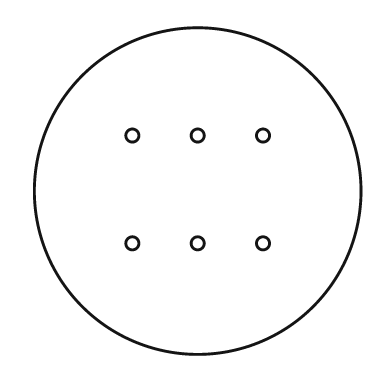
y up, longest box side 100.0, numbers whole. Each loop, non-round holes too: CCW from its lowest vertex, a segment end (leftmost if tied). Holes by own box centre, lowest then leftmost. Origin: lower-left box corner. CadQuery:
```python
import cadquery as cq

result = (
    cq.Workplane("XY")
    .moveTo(50.0, 50.0)
    .circle(50.0)
    .moveTo(30.0, 34.0)
    .circle(2.0)
    .moveTo(50.0, 34.0)
    .circle(2.0)
    .moveTo(70.0, 34.0)
    .circle(2.0)
    .moveTo(30.0, 67.0)
    .circle(2.0)
    .moveTo(50.0, 67.0)
    .circle(2.0)
    .moveTo(70.0, 67.0)
    .circle(2.0)
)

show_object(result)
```